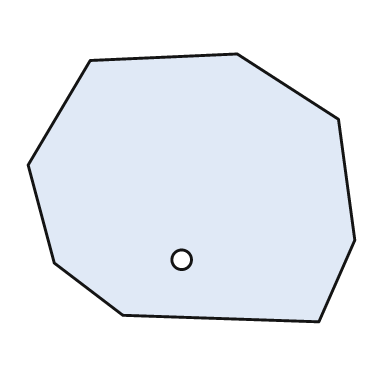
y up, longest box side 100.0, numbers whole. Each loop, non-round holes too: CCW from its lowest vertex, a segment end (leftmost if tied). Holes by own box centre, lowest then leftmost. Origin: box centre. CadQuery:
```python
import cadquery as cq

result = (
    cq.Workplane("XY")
    .moveTo(39.0, -41.0)
    .lineTo(50.0, -16.0)
    .lineTo(45.0, 21.0)
    .lineTo(14.0, 41.0)
    .lineTo(-31.0, 39.0)
    .lineTo(-50.0, 7.0)
    .lineTo(-42.0, -23.0)
    .lineTo(-21.0, -39.0)
    .close()
    .moveTo(-3.0, -22.0)
    .circle(3.0)
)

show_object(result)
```